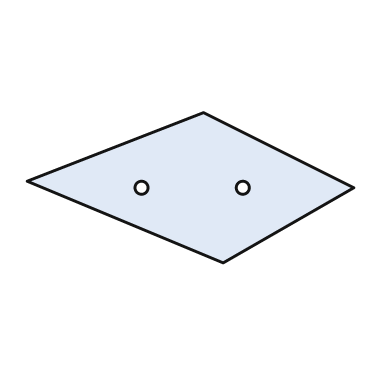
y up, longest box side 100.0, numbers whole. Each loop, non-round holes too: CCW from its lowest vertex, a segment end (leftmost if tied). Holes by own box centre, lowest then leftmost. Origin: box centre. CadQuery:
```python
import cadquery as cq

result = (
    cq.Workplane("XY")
    .moveTo(10.0, -23.0)
    .lineTo(50.0, 0.0)
    .lineTo(4.0, 23.0)
    .lineTo(-50.0, 2.0)
    .close()
    .moveTo(-15.0, 0.0)
    .circle(2.0)
    .moveTo(16.0, 0.0)
    .circle(2.0)
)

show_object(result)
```